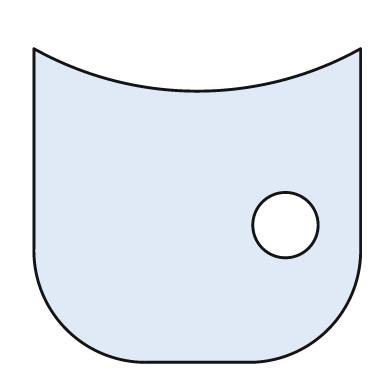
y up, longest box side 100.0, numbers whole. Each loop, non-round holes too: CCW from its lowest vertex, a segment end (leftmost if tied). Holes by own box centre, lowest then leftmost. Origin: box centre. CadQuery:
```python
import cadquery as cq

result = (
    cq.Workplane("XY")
    .moveTo(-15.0, -48.0)
    .lineTo(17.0, -48.0)
    .threePointArc((40.0, -38.0), (50.0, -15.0))
    .lineTo(50.0, 48.0)
    .threePointArc((0.0, 35.0), (-50.0, 48.0))
    .lineTo(-50.0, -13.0)
    .threePointArc((-40.0, -38.0), (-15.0, -48.0))
    .close()
    .moveTo(27.0, -6.0)
    .circle(10.0)
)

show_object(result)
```